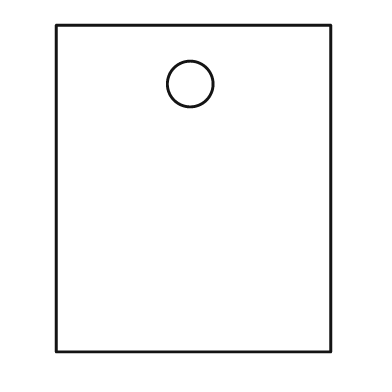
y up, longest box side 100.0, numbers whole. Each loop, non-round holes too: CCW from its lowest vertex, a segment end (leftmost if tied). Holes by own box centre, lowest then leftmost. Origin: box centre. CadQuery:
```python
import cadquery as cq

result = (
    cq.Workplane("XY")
    .moveTo(-42.0, -50.0)
    .lineTo(42.0, -50.0)
    .lineTo(42.0, 50.0)
    .lineTo(-42.0, 50.0)
    .close()
    .moveTo(-1.0, 32.0)
    .circle(7.0)
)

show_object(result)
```